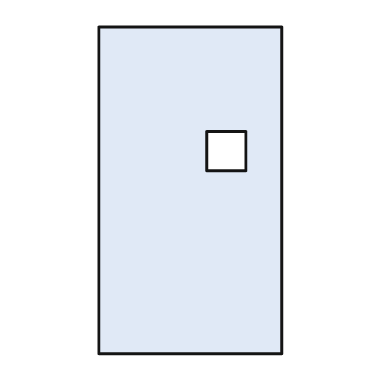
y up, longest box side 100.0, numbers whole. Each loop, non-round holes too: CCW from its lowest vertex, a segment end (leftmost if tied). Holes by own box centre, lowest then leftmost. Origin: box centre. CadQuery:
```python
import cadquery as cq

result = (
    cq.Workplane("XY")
    .moveTo(-28.0, -50.0)
    .lineTo(28.0, -50.0)
    .lineTo(28.0, 50.0)
    .lineTo(-28.0, 50.0)
    .close()
    .moveTo(5.0, 6.0)
    .lineTo(17.0, 6.0)
    .lineTo(17.0, 18.0)
    .lineTo(5.0, 18.0)
    .close()
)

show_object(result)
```